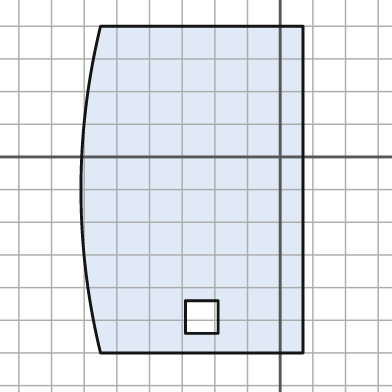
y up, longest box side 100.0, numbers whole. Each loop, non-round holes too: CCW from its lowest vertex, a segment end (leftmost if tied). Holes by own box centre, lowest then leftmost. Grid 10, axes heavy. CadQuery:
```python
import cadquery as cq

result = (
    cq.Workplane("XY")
    .moveTo(-55.0, -60.0)
    .lineTo(7.0, -60.0)
    .lineTo(7.0, 40.0)
    .lineTo(-55.0, 40.0)
    .threePointArc((-61.0, -10.0), (-55.0, -60.0))
    .close()
    .moveTo(-29.0, -54.0)
    .lineTo(-19.0, -54.0)
    .lineTo(-19.0, -44.0)
    .lineTo(-29.0, -44.0)
    .close()
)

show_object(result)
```